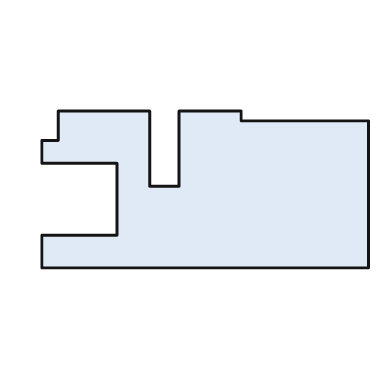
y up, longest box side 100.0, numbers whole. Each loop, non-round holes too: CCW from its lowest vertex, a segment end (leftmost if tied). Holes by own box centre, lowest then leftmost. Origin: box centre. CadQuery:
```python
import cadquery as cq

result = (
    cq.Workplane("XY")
    .moveTo(-50.0, -24.0)
    .lineTo(50.0, -24.0)
    .lineTo(50.0, 21.0)
    .lineTo(11.0, 21.0)
    .lineTo(11.0, 24.0)
    .lineTo(-8.0, 24.0)
    .lineTo(-8.0, 1.0)
    .lineTo(-17.0, 1.0)
    .lineTo(-17.0, 24.0)
    .lineTo(-45.0, 24.0)
    .lineTo(-45.0, 15.0)
    .lineTo(-50.0, 15.0)
    .lineTo(-50.0, 8.0)
    .lineTo(-27.0, 8.0)
    .lineTo(-27.0, -14.0)
    .lineTo(-50.0, -14.0)
    .close()
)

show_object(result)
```